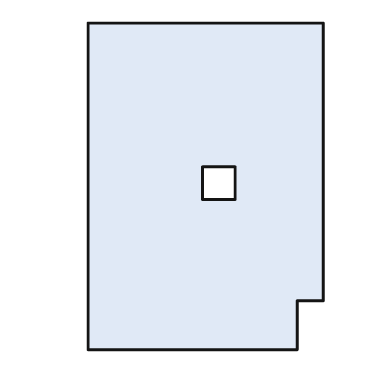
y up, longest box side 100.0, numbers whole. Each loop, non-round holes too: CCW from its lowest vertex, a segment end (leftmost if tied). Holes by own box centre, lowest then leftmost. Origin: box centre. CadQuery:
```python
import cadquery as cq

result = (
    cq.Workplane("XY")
    .moveTo(-36.0, -50.0)
    .lineTo(28.0, -50.0)
    .lineTo(28.0, -35.0)
    .lineTo(36.0, -35.0)
    .lineTo(36.0, 50.0)
    .lineTo(-36.0, 50.0)
    .close()
    .moveTo(-1.0, -4.0)
    .lineTo(9.0, -4.0)
    .lineTo(9.0, 6.0)
    .lineTo(-1.0, 6.0)
    .close()
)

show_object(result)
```